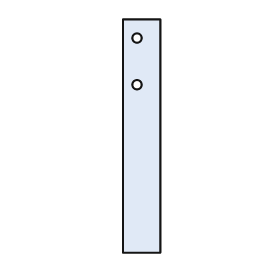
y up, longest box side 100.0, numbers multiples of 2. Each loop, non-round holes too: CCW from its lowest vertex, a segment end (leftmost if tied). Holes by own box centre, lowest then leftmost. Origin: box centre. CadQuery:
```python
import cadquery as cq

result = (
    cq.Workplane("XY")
    .moveTo(-8.0, -50.0)
    .lineTo(8.0, -50.0)
    .lineTo(8.0, 50.0)
    .lineTo(-8.0, 50.0)
    .close()
    .moveTo(-2.0, 22.0)
    .circle(2.0)
    .moveTo(-2.0, 42.0)
    .circle(2.0)
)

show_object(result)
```